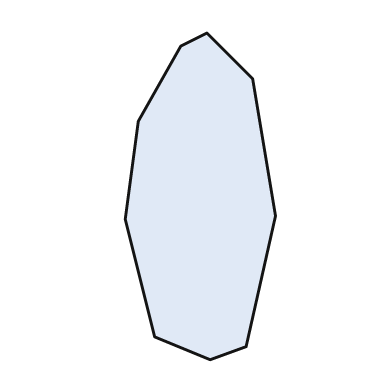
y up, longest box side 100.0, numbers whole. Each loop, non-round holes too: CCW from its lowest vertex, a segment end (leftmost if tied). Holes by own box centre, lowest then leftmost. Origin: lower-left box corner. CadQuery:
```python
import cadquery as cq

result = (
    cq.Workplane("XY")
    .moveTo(26.0, 0.0)
    .lineTo(37.0, 4.0)
    .lineTo(46.0, 44.0)
    .lineTo(39.0, 86.0)
    .lineTo(25.0, 100.0)
    .lineTo(17.0, 96.0)
    .lineTo(4.0, 73.0)
    .lineTo(0.0, 43.0)
    .lineTo(9.0, 7.0)
    .close()
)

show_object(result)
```